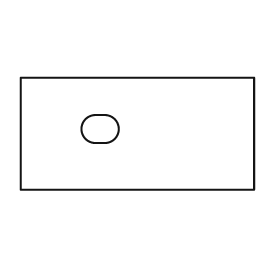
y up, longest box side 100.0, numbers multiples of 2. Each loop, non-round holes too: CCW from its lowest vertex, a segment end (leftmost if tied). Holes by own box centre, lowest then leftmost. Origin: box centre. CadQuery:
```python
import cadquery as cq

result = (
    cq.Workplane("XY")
    .moveTo(-50.0, -24.0)
    .lineTo(50.0, -24.0)
    .lineTo(50.0, 24.0)
    .lineTo(-50.0, 24.0)
    .close()
    .moveTo(-18.0, -4.0)
    .lineTo(-14.0, -4.0)
    .threePointArc((-8.0, 2.0), (-14.0, 8.0))
    .lineTo(-18.0, 8.0)
    .threePointArc((-24.0, 2.0), (-18.0, -4.0))
    .close()
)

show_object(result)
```